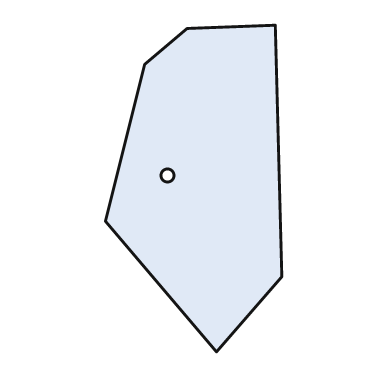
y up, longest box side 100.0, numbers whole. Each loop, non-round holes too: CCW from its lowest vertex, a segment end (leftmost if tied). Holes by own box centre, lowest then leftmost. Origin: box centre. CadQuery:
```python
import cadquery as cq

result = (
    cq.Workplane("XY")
    .moveTo(7.0, -50.0)
    .lineTo(27.0, -27.0)
    .lineTo(25.0, 50.0)
    .lineTo(-2.0, 49.0)
    .lineTo(-15.0, 38.0)
    .lineTo(-27.0, -10.0)
    .close()
    .moveTo(-8.0, 4.0)
    .circle(2.0)
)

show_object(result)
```